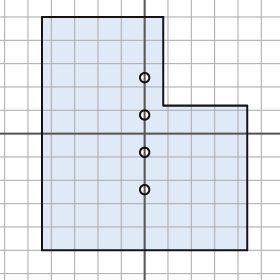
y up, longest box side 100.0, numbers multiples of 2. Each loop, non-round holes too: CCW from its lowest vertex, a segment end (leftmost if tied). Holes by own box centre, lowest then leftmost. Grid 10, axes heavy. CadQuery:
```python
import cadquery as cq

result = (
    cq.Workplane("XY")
    .moveTo(-44.0, -50.0)
    .lineTo(44.0, -50.0)
    .lineTo(44.0, 12.0)
    .lineTo(8.0, 12.0)
    .lineTo(8.0, 50.0)
    .lineTo(-44.0, 50.0)
    .close()
    .moveTo(0.0, -24.0)
    .circle(2.0)
    .moveTo(0.0, -8.0)
    .circle(2.0)
    .moveTo(0.0, 8.0)
    .circle(2.0)
    .moveTo(0.0, 24.0)
    .circle(2.0)
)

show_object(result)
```